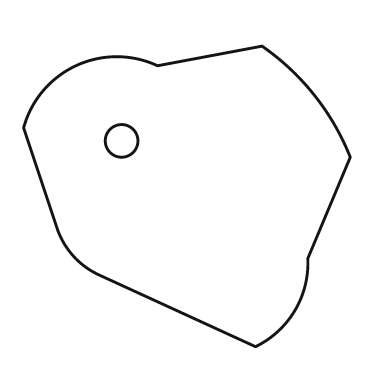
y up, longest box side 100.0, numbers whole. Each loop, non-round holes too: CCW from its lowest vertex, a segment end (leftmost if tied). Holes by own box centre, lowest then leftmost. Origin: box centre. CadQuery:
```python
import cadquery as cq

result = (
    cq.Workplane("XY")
    .moveTo(21.0, -46.0)
    .threePointArc((33.0, -35.0), (37.0, -19.0))
    .lineTo(50.0, 12.0)
    .threePointArc((39.0, 31.0), (23.0, 46.0))
    .lineTo(-9.0, 40.0)
    .threePointArc((-34.0, 40.0), (-50.0, 21.0))
    .lineTo(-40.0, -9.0)
    .threePointArc((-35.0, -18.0), (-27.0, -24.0))
    .close()
    .moveTo(-20.0, 17.0)
    .circle(5.0)
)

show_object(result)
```